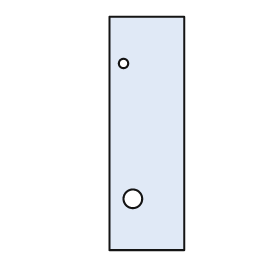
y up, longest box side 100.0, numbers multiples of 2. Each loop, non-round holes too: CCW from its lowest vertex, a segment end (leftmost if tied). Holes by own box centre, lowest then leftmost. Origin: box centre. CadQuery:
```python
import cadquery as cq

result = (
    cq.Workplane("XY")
    .moveTo(-16.0, -50.0)
    .lineTo(16.0, -50.0)
    .lineTo(16.0, 50.0)
    .lineTo(-16.0, 50.0)
    .close()
    .moveTo(-6.0, -28.0)
    .circle(4.0)
    .moveTo(-10.0, 30.0)
    .circle(2.0)
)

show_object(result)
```